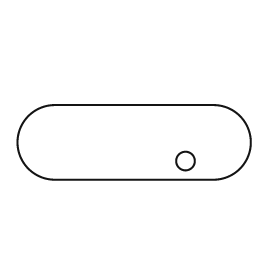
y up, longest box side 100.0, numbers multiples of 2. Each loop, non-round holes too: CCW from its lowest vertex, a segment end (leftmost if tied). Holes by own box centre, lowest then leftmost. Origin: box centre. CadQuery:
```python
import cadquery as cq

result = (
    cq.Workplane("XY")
    .moveTo(-34.0, -16.0)
    .lineTo(34.0, -16.0)
    .threePointArc((50.0, 0.0), (34.0, 16.0))
    .lineTo(-34.0, 16.0)
    .threePointArc((-50.0, 0.0), (-34.0, -16.0))
    .close()
    .moveTo(22.0, -8.0)
    .circle(4.0)
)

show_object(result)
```